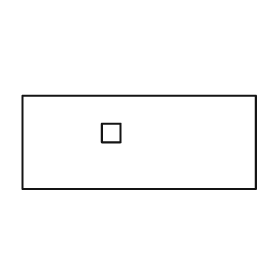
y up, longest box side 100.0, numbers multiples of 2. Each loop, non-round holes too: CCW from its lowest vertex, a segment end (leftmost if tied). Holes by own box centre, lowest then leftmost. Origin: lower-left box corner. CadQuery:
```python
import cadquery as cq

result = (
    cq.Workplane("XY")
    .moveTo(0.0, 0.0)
    .lineTo(100.0, 0.0)
    .lineTo(100.0, 40.0)
    .lineTo(0.0, 40.0)
    .close()
    .moveTo(34.0, 20.0)
    .lineTo(42.0, 20.0)
    .lineTo(42.0, 28.0)
    .lineTo(34.0, 28.0)
    .close()
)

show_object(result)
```